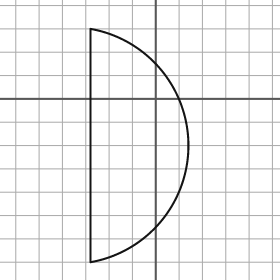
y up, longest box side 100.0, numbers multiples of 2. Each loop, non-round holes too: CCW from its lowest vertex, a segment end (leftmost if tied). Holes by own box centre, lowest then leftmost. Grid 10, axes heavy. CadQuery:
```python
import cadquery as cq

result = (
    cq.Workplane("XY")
    .moveTo(-28.0, -70.0)
    .threePointArc((14.0, -20.0), (-28.0, 30.0))
    .close()
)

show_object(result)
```